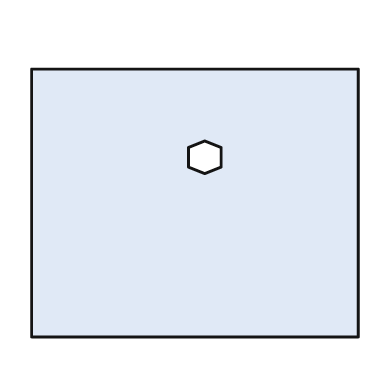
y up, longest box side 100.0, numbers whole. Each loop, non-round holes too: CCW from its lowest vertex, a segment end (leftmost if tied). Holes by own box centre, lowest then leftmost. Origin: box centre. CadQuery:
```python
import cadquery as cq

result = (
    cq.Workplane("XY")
    .moveTo(-50.0, -41.0)
    .lineTo(50.0, -41.0)
    .lineTo(50.0, 41.0)
    .lineTo(-50.0, 41.0)
    .close()
    .moveTo(3.0, 9.0)
    .lineTo(8.0, 11.0)
    .lineTo(8.0, 17.0)
    .lineTo(3.0, 19.0)
    .lineTo(-2.0, 17.0)
    .lineTo(-2.0, 11.0)
    .close()
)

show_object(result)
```